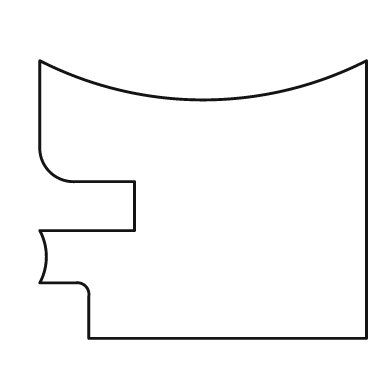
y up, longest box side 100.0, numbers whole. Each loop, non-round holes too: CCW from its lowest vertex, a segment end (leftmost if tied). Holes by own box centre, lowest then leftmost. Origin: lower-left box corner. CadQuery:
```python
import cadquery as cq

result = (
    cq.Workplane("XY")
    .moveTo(15.0, 0.0)
    .lineTo(100.0, 0.0)
    .lineTo(100.0, 85.0)
    .threePointArc((50.0, 73.0), (0.0, 85.0))
    .lineTo(0.0, 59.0)
    .threePointArc((3.0, 51.0), (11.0, 48.0))
    .lineTo(29.0, 48.0)
    .lineTo(29.0, 33.0)
    .lineTo(0.0, 33.0)
    .threePointArc((2.0, 25.0), (0.0, 17.0))
    .lineTo(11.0, 17.0)
    .threePointArc((14.0, 16.0), (15.0, 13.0))
    .close()
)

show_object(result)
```